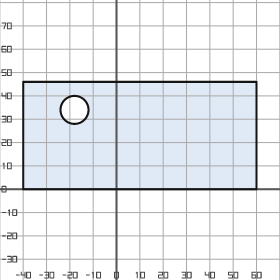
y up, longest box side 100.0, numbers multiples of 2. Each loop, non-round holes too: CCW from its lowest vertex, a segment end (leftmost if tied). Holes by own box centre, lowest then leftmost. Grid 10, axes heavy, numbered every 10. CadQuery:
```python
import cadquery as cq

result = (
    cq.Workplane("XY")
    .moveTo(-40.0, 0.0)
    .lineTo(60.0, 0.0)
    .lineTo(60.0, 46.0)
    .lineTo(-40.0, 46.0)
    .close()
    .moveTo(-18.0, 34.0)
    .circle(6.0)
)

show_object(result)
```